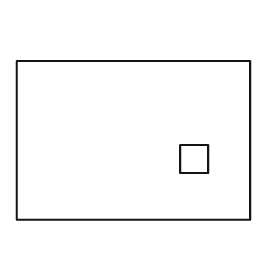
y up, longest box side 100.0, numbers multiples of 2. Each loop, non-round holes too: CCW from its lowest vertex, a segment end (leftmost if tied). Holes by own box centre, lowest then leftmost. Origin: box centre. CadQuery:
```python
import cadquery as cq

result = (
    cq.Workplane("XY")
    .moveTo(-50.0, -34.0)
    .lineTo(50.0, -34.0)
    .lineTo(50.0, 34.0)
    .lineTo(-50.0, 34.0)
    .close()
    .moveTo(20.0, -14.0)
    .lineTo(32.0, -14.0)
    .lineTo(32.0, -2.0)
    .lineTo(20.0, -2.0)
    .close()
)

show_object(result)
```